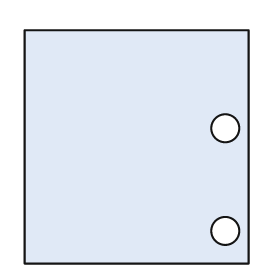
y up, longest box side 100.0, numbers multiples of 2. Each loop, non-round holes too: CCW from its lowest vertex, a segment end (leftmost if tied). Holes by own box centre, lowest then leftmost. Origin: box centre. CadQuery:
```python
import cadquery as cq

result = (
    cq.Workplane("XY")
    .moveTo(-48.0, -50.0)
    .lineTo(48.0, -50.0)
    .lineTo(48.0, 50.0)
    .lineTo(-48.0, 50.0)
    .close()
    .moveTo(38.0, -36.0)
    .circle(6.0)
    .moveTo(38.0, 8.0)
    .circle(6.0)
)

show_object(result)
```